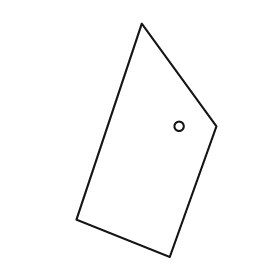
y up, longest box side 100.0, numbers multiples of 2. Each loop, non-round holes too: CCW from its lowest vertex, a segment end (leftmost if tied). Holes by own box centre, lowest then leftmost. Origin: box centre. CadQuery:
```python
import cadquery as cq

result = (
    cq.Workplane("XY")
    .moveTo(10.0, -50.0)
    .lineTo(30.0, 6.0)
    .lineTo(-2.0, 50.0)
    .lineTo(-30.0, -34.0)
    .close()
    .moveTo(14.0, 6.0)
    .circle(2.0)
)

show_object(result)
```